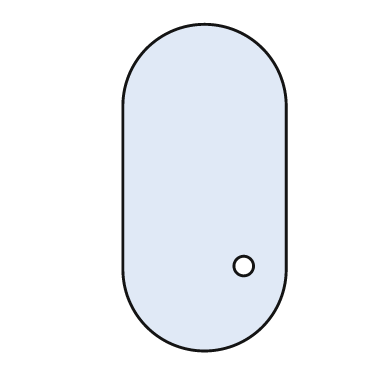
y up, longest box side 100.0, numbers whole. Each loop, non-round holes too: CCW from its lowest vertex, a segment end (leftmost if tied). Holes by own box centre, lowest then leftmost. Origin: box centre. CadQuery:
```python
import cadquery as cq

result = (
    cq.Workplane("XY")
    .moveTo(-25.0, -25.0)
    .threePointArc((0.0, -50.0), (25.0, -25.0))
    .lineTo(25.0, 25.0)
    .threePointArc((0.0, 50.0), (-25.0, 25.0))
    .close()
    .moveTo(12.0, -24.0)
    .circle(3.0)
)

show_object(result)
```